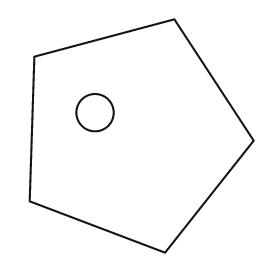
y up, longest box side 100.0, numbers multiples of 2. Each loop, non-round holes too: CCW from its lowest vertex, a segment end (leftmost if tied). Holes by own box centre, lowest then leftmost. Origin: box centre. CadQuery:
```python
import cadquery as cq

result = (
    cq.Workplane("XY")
    .moveTo(10.0, -50.0)
    .lineTo(48.0, -2.0)
    .lineTo(14.0, 50.0)
    .lineTo(-46.0, 34.0)
    .lineTo(-48.0, -28.0)
    .close()
    .moveTo(-20.0, 10.0)
    .circle(8.0)
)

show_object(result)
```